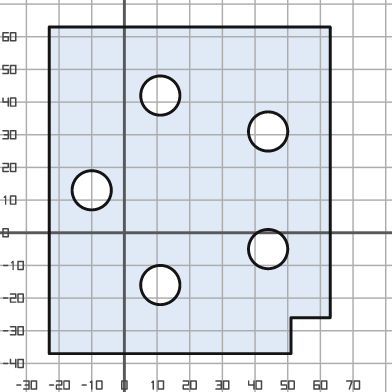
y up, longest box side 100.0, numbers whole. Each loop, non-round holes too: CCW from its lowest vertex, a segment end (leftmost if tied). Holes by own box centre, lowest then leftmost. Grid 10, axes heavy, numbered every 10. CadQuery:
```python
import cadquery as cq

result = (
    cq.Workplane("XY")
    .moveTo(-23.0, -37.0)
    .lineTo(51.0, -37.0)
    .lineTo(51.0, -26.0)
    .lineTo(63.0, -26.0)
    .lineTo(63.0, 63.0)
    .lineTo(-23.0, 63.0)
    .close()
    .moveTo(11.0, -16.0)
    .circle(6.0)
    .moveTo(44.0, -5.0)
    .circle(6.0)
    .moveTo(-10.0, 13.0)
    .circle(6.0)
    .moveTo(44.0, 31.0)
    .circle(6.0)
    .moveTo(11.0, 42.0)
    .circle(6.0)
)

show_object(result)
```